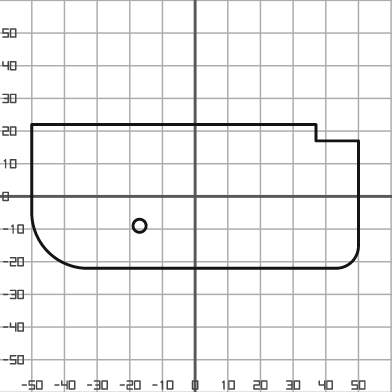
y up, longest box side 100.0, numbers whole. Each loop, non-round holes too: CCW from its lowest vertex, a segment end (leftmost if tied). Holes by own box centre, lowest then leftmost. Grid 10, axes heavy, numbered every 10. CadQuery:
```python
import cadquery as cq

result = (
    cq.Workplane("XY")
    .moveTo(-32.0, -22.0)
    .lineTo(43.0, -22.0)
    .threePointArc((48.0, -20.0), (50.0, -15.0))
    .lineTo(50.0, 17.0)
    .lineTo(37.0, 17.0)
    .lineTo(37.0, 22.0)
    .lineTo(-50.0, 22.0)
    .lineTo(-50.0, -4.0)
    .threePointArc((-45.0, -17.0), (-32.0, -22.0))
    .close()
    .moveTo(-17.0, -9.0)
    .circle(2.0)
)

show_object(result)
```